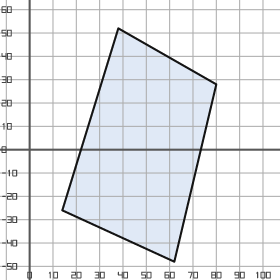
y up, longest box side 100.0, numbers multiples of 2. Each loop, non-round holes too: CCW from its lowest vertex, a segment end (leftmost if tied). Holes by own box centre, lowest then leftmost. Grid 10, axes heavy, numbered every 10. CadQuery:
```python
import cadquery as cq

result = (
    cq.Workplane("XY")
    .moveTo(62.0, -48.0)
    .lineTo(80.0, 28.0)
    .lineTo(38.0, 52.0)
    .lineTo(14.0, -26.0)
    .close()
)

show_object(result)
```